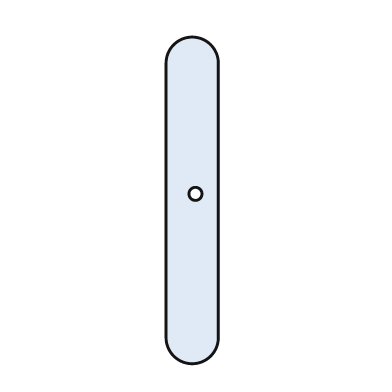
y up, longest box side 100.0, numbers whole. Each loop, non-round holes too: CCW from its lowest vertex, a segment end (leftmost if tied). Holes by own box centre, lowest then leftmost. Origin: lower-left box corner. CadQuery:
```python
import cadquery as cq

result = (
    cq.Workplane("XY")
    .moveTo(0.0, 8.0)
    .threePointArc((8.0, 0.0), (16.0, 8.0))
    .lineTo(16.0, 92.0)
    .threePointArc((8.0, 100.0), (0.0, 92.0))
    .close()
    .moveTo(9.0, 52.0)
    .circle(2.0)
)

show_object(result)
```